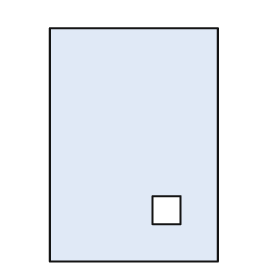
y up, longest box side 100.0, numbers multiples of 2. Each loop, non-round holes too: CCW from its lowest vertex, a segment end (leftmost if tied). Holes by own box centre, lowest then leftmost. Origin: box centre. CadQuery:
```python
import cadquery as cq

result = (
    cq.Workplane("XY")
    .moveTo(-36.0, -50.0)
    .lineTo(36.0, -50.0)
    .lineTo(36.0, 50.0)
    .lineTo(-36.0, 50.0)
    .close()
    .moveTo(8.0, -34.0)
    .lineTo(20.0, -34.0)
    .lineTo(20.0, -22.0)
    .lineTo(8.0, -22.0)
    .close()
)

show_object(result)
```